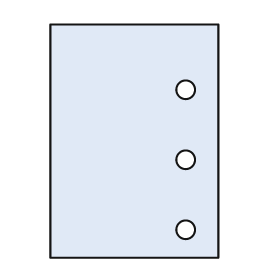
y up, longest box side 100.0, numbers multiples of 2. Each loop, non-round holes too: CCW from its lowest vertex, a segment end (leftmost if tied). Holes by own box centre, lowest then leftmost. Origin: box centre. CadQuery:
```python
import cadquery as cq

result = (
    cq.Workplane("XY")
    .moveTo(-36.0, -50.0)
    .lineTo(36.0, -50.0)
    .lineTo(36.0, 50.0)
    .lineTo(-36.0, 50.0)
    .close()
    .moveTo(22.0, -38.0)
    .circle(4.0)
    .moveTo(22.0, -8.0)
    .circle(4.0)
    .moveTo(22.0, 22.0)
    .circle(4.0)
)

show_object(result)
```